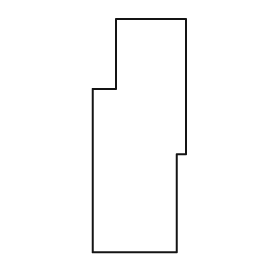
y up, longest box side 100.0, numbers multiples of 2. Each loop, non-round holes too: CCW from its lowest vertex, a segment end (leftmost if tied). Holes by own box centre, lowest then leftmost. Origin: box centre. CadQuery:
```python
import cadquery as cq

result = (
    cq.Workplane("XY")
    .moveTo(-20.0, -50.0)
    .lineTo(16.0, -50.0)
    .lineTo(16.0, -8.0)
    .lineTo(20.0, -8.0)
    .lineTo(20.0, 50.0)
    .lineTo(-10.0, 50.0)
    .lineTo(-10.0, 20.0)
    .lineTo(-20.0, 20.0)
    .close()
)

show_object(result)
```